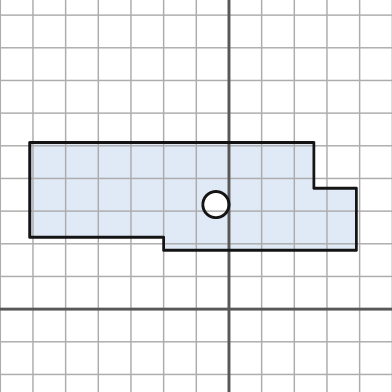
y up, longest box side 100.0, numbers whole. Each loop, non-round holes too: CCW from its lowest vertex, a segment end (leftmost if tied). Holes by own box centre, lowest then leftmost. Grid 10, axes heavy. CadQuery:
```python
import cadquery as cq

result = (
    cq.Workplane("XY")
    .moveTo(-20.0, 18.0)
    .lineTo(39.0, 18.0)
    .lineTo(39.0, 37.0)
    .lineTo(26.0, 37.0)
    .lineTo(26.0, 51.0)
    .lineTo(-61.0, 51.0)
    .lineTo(-61.0, 22.0)
    .lineTo(-20.0, 22.0)
    .close()
    .moveTo(-4.0, 32.0)
    .circle(4.0)
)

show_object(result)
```